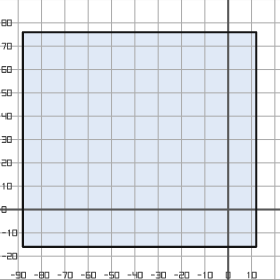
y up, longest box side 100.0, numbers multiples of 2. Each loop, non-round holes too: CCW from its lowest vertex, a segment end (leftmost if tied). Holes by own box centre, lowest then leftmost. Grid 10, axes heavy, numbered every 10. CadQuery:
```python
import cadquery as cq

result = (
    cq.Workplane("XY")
    .moveTo(-88.0, -16.0)
    .lineTo(12.0, -16.0)
    .lineTo(12.0, 76.0)
    .lineTo(-88.0, 76.0)
    .close()
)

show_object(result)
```